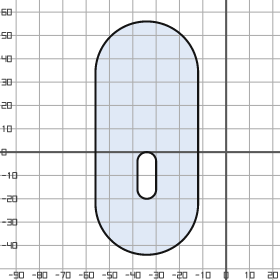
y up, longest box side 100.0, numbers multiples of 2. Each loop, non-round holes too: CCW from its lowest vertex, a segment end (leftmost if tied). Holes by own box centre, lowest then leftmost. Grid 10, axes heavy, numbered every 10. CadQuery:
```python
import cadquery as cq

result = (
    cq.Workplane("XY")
    .moveTo(-56.0, -22.0)
    .threePointArc((-34.0, -44.0), (-12.0, -22.0))
    .lineTo(-12.0, 34.0)
    .threePointArc((-34.0, 56.0), (-56.0, 34.0))
    .close()
    .moveTo(-38.0, -16.0)
    .threePointArc((-34.0, -20.0), (-30.0, -16.0))
    .lineTo(-30.0, -4.0)
    .threePointArc((-34.0, 0.0), (-38.0, -4.0))
    .close()
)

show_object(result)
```